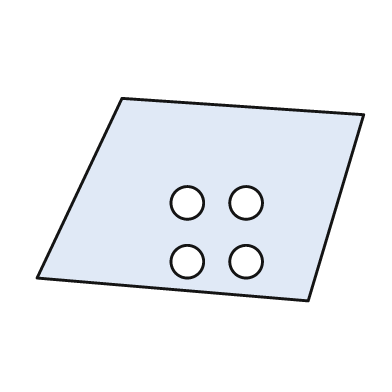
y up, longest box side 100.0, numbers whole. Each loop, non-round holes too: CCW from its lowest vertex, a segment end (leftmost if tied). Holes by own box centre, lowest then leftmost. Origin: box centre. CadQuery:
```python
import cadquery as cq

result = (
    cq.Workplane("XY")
    .moveTo(33.0, -31.0)
    .lineTo(50.0, 26.0)
    .lineTo(-24.0, 31.0)
    .lineTo(-50.0, -24.0)
    .close()
    .moveTo(-4.0, -19.0)
    .circle(5.0)
    .moveTo(14.0, -19.0)
    .circle(5.0)
    .moveTo(-4.0, -1.0)
    .circle(5.0)
    .moveTo(14.0, -1.0)
    .circle(5.0)
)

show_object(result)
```